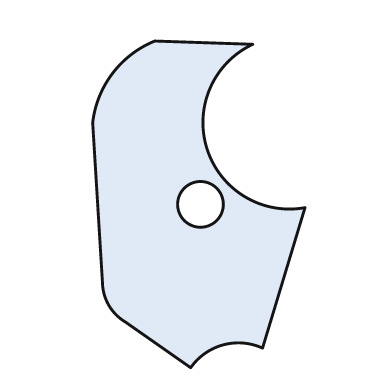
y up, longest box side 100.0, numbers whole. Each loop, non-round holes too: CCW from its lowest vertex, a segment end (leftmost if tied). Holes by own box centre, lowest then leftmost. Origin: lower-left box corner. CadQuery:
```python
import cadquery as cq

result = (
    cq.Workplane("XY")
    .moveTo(30.0, 0.0)
    .threePointArc((40.0, 7.0), (52.0, 6.0))
    .lineTo(65.0, 49.0)
    .threePointArc((35.0, 67.0), (49.0, 99.0))
    .lineTo(19.0, 100.0)
    .threePointArc((6.0, 90.0), (0.0, 75.0))
    .lineTo(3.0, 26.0)
    .threePointArc((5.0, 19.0), (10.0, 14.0))
    .close()
    .moveTo(33.0, 50.0)
    .circle(7.0)
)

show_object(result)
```